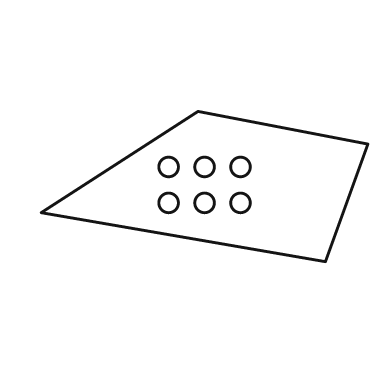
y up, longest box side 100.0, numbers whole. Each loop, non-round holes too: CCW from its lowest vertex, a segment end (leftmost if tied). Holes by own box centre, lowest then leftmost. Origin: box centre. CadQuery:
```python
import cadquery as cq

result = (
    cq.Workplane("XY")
    .moveTo(37.0, -23.0)
    .lineTo(50.0, 13.0)
    .lineTo(-2.0, 23.0)
    .lineTo(-50.0, -8.0)
    .close()
    .moveTo(-11.0, -5.0)
    .circle(3.0)
    .moveTo(0.0, -5.0)
    .circle(3.0)
    .moveTo(11.0, -5.0)
    .circle(3.0)
    .moveTo(-11.0, 6.0)
    .circle(3.0)
    .moveTo(0.0, 6.0)
    .circle(3.0)
    .moveTo(11.0, 6.0)
    .circle(3.0)
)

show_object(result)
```